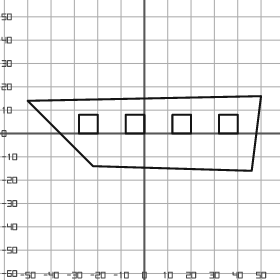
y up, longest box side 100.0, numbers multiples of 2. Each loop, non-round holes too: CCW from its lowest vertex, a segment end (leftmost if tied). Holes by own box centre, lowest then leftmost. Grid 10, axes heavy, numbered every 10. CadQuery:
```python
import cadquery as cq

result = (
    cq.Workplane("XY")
    .moveTo(46.0, -16.0)
    .lineTo(50.0, 16.0)
    .lineTo(-50.0, 14.0)
    .lineTo(-22.0, -14.0)
    .close()
    .moveTo(-28.0, 0.0)
    .lineTo(-20.0, 0.0)
    .lineTo(-20.0, 8.0)
    .lineTo(-28.0, 8.0)
    .close()
    .moveTo(-8.0, 0.0)
    .lineTo(0.0, 0.0)
    .lineTo(0.0, 8.0)
    .lineTo(-8.0, 8.0)
    .close()
    .moveTo(12.0, 0.0)
    .lineTo(20.0, 0.0)
    .lineTo(20.0, 8.0)
    .lineTo(12.0, 8.0)
    .close()
    .moveTo(32.0, 0.0)
    .lineTo(40.0, 0.0)
    .lineTo(40.0, 8.0)
    .lineTo(32.0, 8.0)
    .close()
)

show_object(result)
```